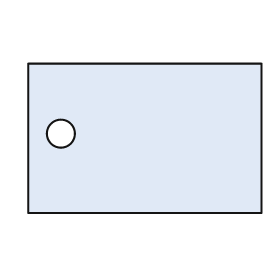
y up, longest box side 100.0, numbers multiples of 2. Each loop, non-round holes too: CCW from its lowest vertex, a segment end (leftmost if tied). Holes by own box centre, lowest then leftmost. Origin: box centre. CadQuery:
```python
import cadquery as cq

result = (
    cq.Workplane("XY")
    .moveTo(-50.0, -32.0)
    .lineTo(50.0, -32.0)
    .lineTo(50.0, 32.0)
    .lineTo(-50.0, 32.0)
    .close()
    .moveTo(-36.0, 2.0)
    .circle(6.0)
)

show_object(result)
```